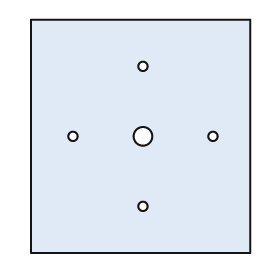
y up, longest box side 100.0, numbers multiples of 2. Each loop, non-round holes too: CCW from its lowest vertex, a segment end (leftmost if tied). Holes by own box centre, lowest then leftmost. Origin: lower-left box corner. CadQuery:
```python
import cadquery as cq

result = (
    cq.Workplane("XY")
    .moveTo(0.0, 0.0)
    .lineTo(94.0, 0.0)
    .lineTo(94.0, 100.0)
    .lineTo(0.0, 100.0)
    .close()
    .moveTo(48.0, 20.0)
    .circle(2.0)
    .moveTo(18.0, 50.0)
    .circle(2.0)
    .moveTo(48.0, 50.0)
    .circle(4.0)
    .moveTo(78.0, 50.0)
    .circle(2.0)
    .moveTo(48.0, 80.0)
    .circle(2.0)
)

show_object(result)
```